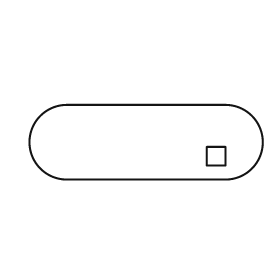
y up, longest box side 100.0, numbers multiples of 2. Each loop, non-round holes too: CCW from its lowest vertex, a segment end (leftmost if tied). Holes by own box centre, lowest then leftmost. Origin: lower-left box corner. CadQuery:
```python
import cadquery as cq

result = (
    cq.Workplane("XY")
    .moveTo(16.0, 0.0)
    .lineTo(84.0, 0.0)
    .threePointArc((100.0, 16.0), (84.0, 32.0))
    .lineTo(16.0, 32.0)
    .threePointArc((0.0, 16.0), (16.0, 0.0))
    .close()
    .moveTo(76.0, 6.0)
    .lineTo(84.0, 6.0)
    .lineTo(84.0, 14.0)
    .lineTo(76.0, 14.0)
    .close()
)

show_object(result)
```